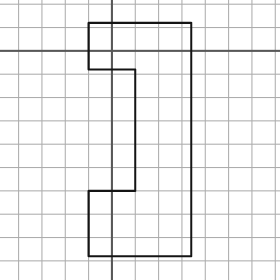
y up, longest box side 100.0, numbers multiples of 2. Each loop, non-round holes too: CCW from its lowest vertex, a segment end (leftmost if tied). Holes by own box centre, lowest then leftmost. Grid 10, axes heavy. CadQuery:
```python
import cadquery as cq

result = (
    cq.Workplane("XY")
    .moveTo(-10.0, -88.0)
    .lineTo(34.0, -88.0)
    .lineTo(34.0, 12.0)
    .lineTo(-10.0, 12.0)
    .lineTo(-10.0, -8.0)
    .lineTo(10.0, -8.0)
    .lineTo(10.0, -60.0)
    .lineTo(-10.0, -60.0)
    .close()
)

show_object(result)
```